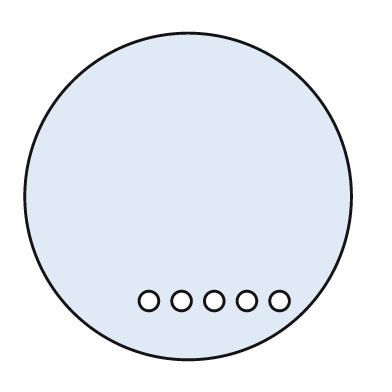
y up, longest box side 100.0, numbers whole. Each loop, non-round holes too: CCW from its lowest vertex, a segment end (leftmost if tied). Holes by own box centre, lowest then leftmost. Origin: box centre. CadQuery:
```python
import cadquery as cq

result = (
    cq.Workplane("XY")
    .moveTo(0.0, 0.0)
    .circle(50.0)
    .moveTo(-12.0, -32.0)
    .circle(3.0)
    .moveTo(-2.0, -32.0)
    .circle(3.0)
    .moveTo(8.0, -32.0)
    .circle(3.0)
    .moveTo(18.0, -32.0)
    .circle(3.0)
    .moveTo(28.0, -32.0)
    .circle(3.0)
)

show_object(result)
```